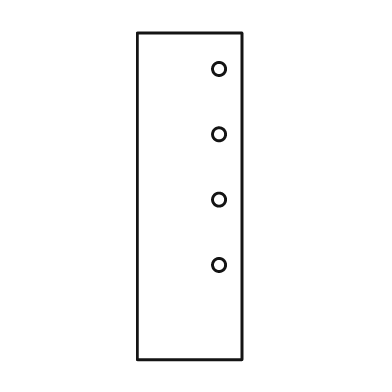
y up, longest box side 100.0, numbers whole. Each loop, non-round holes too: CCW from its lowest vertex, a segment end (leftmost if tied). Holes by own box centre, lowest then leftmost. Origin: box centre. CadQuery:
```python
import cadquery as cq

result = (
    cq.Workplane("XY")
    .moveTo(-16.0, -50.0)
    .lineTo(16.0, -50.0)
    .lineTo(16.0, 50.0)
    .lineTo(-16.0, 50.0)
    .close()
    .moveTo(9.0, -21.0)
    .circle(2.0)
    .moveTo(9.0, -1.0)
    .circle(2.0)
    .moveTo(9.0, 19.0)
    .circle(2.0)
    .moveTo(9.0, 39.0)
    .circle(2.0)
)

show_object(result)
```